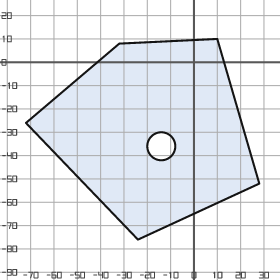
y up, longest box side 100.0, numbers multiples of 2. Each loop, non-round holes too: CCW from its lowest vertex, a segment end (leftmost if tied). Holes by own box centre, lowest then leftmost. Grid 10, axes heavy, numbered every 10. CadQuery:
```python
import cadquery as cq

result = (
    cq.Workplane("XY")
    .moveTo(-24.0, -76.0)
    .lineTo(28.0, -52.0)
    .lineTo(10.0, 10.0)
    .lineTo(-32.0, 8.0)
    .lineTo(-72.0, -26.0)
    .close()
    .moveTo(-14.0, -36.0)
    .circle(6.0)
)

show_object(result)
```